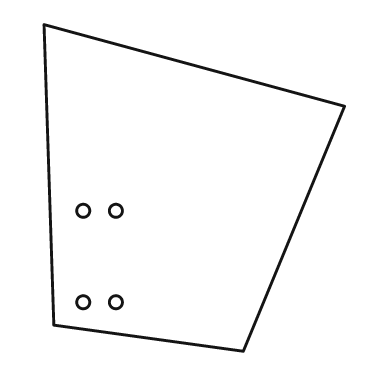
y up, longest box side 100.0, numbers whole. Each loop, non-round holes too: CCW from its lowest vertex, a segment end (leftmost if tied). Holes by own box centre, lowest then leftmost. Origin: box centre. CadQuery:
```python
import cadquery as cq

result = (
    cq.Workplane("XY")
    .moveTo(15.0, -50.0)
    .lineTo(46.0, 25.0)
    .lineTo(-46.0, 50.0)
    .lineTo(-43.0, -42.0)
    .close()
    .moveTo(-34.0, -35.0)
    .circle(2.0)
    .moveTo(-24.0, -35.0)
    .circle(2.0)
    .moveTo(-34.0, -7.0)
    .circle(2.0)
    .moveTo(-24.0, -7.0)
    .circle(2.0)
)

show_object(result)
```